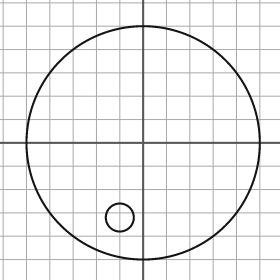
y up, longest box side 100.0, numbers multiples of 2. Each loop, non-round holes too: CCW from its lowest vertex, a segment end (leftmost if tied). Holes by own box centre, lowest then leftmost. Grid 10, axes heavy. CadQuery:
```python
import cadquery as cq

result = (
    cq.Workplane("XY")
    .moveTo(0.0, 0.0)
    .circle(50.0)
    .moveTo(-10.0, -32.0)
    .circle(6.0)
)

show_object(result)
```